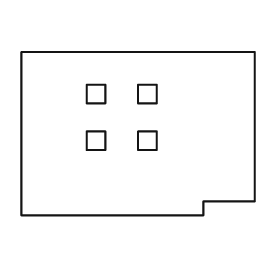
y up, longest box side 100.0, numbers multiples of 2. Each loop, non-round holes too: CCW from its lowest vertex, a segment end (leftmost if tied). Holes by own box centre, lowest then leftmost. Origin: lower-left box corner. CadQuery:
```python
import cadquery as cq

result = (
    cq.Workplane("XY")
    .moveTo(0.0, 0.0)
    .lineTo(78.0, 0.0)
    .lineTo(78.0, 6.0)
    .lineTo(100.0, 6.0)
    .lineTo(100.0, 70.0)
    .lineTo(0.0, 70.0)
    .close()
    .moveTo(28.0, 28.0)
    .lineTo(36.0, 28.0)
    .lineTo(36.0, 36.0)
    .lineTo(28.0, 36.0)
    .close()
    .moveTo(50.0, 28.0)
    .lineTo(58.0, 28.0)
    .lineTo(58.0, 36.0)
    .lineTo(50.0, 36.0)
    .close()
    .moveTo(28.0, 48.0)
    .lineTo(36.0, 48.0)
    .lineTo(36.0, 56.0)
    .lineTo(28.0, 56.0)
    .close()
    .moveTo(50.0, 48.0)
    .lineTo(58.0, 48.0)
    .lineTo(58.0, 56.0)
    .lineTo(50.0, 56.0)
    .close()
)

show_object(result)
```